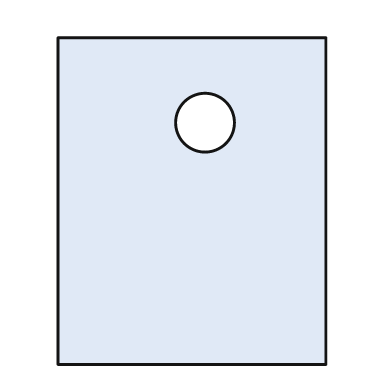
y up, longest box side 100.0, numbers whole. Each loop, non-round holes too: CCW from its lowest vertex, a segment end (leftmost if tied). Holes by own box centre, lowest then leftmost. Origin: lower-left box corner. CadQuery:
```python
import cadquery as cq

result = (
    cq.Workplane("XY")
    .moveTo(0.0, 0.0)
    .lineTo(82.0, 0.0)
    .lineTo(82.0, 100.0)
    .lineTo(0.0, 100.0)
    .close()
    .moveTo(45.0, 74.0)
    .circle(9.0)
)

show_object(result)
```